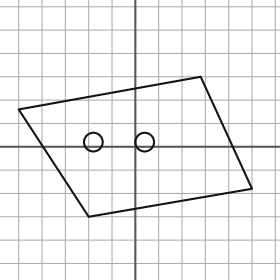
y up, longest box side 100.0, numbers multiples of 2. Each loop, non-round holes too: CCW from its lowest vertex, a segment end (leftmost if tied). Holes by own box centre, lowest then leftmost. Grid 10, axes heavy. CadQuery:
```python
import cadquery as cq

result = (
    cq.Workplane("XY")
    .moveTo(-20.0, -30.0)
    .lineTo(50.0, -18.0)
    .lineTo(28.0, 30.0)
    .lineTo(-50.0, 16.0)
    .close()
    .moveTo(-18.0, 2.0)
    .circle(4.0)
    .moveTo(4.0, 2.0)
    .circle(4.0)
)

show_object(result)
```